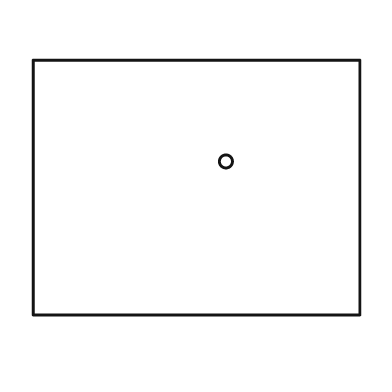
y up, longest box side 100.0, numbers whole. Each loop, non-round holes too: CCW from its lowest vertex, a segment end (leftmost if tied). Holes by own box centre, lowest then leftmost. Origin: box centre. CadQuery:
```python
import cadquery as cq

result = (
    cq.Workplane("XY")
    .moveTo(-50.0, -39.0)
    .lineTo(50.0, -39.0)
    .lineTo(50.0, 39.0)
    .lineTo(-50.0, 39.0)
    .close()
    .moveTo(9.0, 8.0)
    .circle(2.0)
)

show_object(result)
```